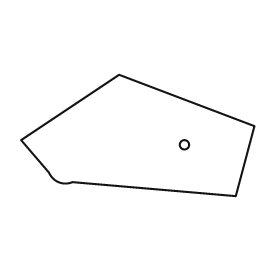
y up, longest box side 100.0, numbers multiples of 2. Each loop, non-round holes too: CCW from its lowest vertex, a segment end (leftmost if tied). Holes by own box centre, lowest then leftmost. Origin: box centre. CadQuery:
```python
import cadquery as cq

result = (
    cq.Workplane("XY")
    .moveTo(42.0, -26.0)
    .lineTo(50.0, 4.0)
    .lineTo(-8.0, 26.0)
    .lineTo(-50.0, -2.0)
    .lineTo(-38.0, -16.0)
    .threePointArc((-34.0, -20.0), (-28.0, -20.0))
    .close()
    .moveTo(20.0, -4.0)
    .circle(2.0)
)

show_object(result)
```